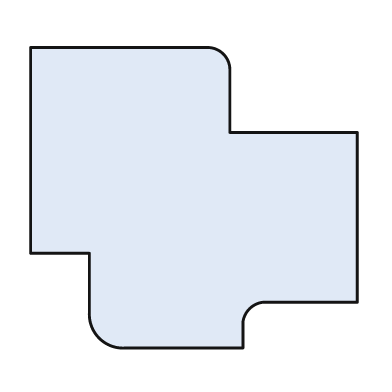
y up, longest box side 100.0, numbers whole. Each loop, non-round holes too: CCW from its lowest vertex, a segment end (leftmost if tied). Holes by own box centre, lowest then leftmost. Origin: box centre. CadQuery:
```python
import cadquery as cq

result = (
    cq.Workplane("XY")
    .moveTo(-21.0, -46.0)
    .lineTo(15.0, -46.0)
    .lineTo(15.0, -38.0)
    .threePointArc((17.0, -34.0), (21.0, -32.0))
    .lineTo(50.0, -32.0)
    .lineTo(50.0, 20.0)
    .lineTo(11.0, 20.0)
    .lineTo(11.0, 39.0)
    .threePointArc((9.0, 44.0), (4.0, 46.0))
    .lineTo(-50.0, 46.0)
    .lineTo(-50.0, -17.0)
    .lineTo(-32.0, -17.0)
    .lineTo(-32.0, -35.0)
    .threePointArc((-29.0, -43.0), (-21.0, -46.0))
    .close()
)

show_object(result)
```